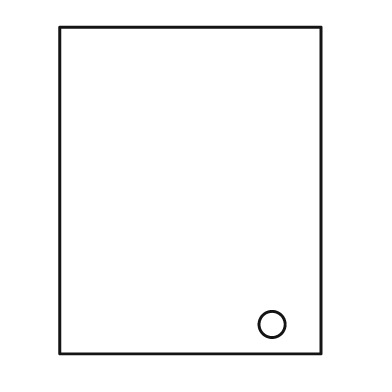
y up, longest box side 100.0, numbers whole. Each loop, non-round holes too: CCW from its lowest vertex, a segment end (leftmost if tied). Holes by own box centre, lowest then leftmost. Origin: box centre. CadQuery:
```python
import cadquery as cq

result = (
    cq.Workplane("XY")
    .moveTo(-40.0, -50.0)
    .lineTo(40.0, -50.0)
    .lineTo(40.0, 50.0)
    .lineTo(-40.0, 50.0)
    .close()
    .moveTo(25.0, -41.0)
    .circle(4.0)
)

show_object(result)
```